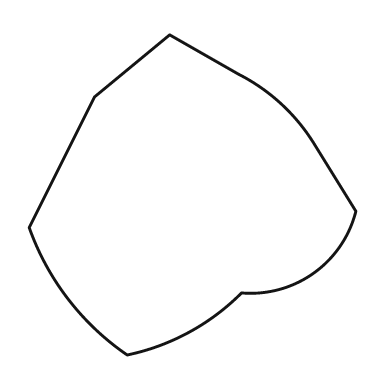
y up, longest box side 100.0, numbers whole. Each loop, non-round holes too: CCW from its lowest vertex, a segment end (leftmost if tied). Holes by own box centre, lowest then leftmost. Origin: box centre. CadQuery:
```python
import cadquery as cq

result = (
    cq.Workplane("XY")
    .moveTo(-20.0, -49.0)
    .threePointArc((-1.0, -42.0), (15.0, -30.0))
    .threePointArc((37.0, -24.0), (50.0, -5.0))
    .lineTo(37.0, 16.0)
    .threePointArc((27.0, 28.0), (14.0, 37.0))
    .lineTo(-7.0, 49.0)
    .lineTo(-30.0, 30.0)
    .lineTo(-50.0, -10.0)
    .threePointArc((-38.0, -32.0), (-20.0, -49.0))
    .close()
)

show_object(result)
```